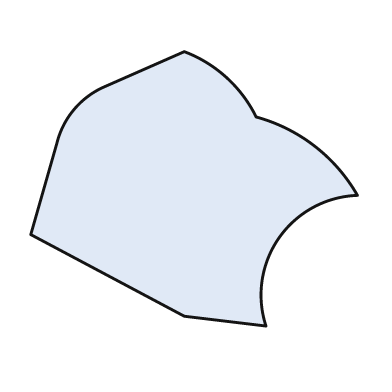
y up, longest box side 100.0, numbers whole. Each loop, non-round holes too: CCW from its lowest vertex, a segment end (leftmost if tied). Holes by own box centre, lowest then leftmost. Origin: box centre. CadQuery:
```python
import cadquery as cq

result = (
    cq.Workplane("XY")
    .moveTo(22.0, -42.0)
    .threePointArc((26.0, -15.0), (50.0, -2.0))
    .threePointArc((37.0, 13.0), (19.0, 22.0))
    .threePointArc((10.0, 34.0), (-3.0, 42.0))
    .lineTo(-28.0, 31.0)
    .threePointArc((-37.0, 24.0), (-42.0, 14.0))
    .lineTo(-50.0, -14.0)
    .lineTo(-3.0, -39.0)
    .close()
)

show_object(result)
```